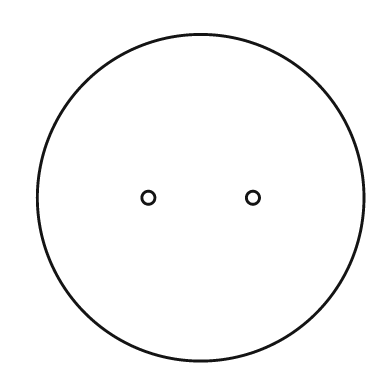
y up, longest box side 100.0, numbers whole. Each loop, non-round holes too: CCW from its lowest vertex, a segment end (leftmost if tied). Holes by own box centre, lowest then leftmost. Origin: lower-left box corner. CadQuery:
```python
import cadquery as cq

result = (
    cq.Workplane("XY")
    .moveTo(50.0, 50.0)
    .circle(50.0)
    .moveTo(34.0, 50.0)
    .circle(2.0)
    .moveTo(66.0, 50.0)
    .circle(2.0)
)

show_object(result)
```